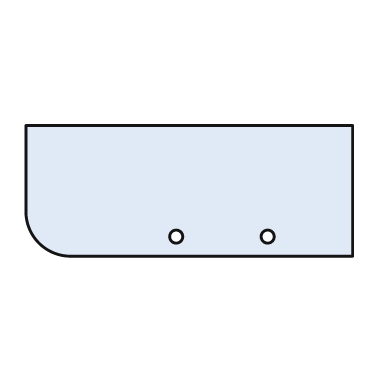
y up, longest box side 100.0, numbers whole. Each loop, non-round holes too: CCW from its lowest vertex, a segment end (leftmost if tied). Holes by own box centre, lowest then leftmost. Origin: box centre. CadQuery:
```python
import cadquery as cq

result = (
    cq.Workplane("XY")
    .moveTo(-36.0, -20.0)
    .lineTo(50.0, -20.0)
    .lineTo(50.0, 20.0)
    .lineTo(-50.0, 20.0)
    .lineTo(-50.0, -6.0)
    .threePointArc((-46.0, -16.0), (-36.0, -20.0))
    .close()
    .moveTo(-4.0, -14.0)
    .circle(2.0)
    .moveTo(24.0, -14.0)
    .circle(2.0)
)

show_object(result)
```